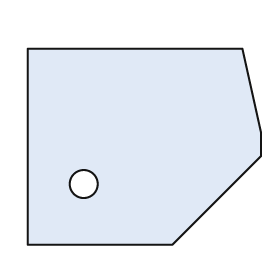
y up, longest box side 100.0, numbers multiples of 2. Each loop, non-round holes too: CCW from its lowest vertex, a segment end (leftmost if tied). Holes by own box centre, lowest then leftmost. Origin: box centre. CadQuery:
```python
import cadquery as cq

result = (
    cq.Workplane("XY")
    .moveTo(-50.0, -42.0)
    .lineTo(12.0, -42.0)
    .lineTo(50.0, -4.0)
    .lineTo(50.0, 6.0)
    .lineTo(42.0, 42.0)
    .lineTo(-50.0, 42.0)
    .close()
    .moveTo(-26.0, -16.0)
    .circle(6.0)
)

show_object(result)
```